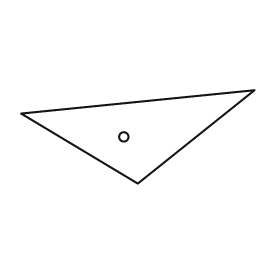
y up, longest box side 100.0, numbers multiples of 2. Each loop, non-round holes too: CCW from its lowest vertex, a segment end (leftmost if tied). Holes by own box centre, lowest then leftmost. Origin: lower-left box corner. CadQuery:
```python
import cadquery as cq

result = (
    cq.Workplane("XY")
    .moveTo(50.0, 0.0)
    .lineTo(100.0, 40.0)
    .lineTo(0.0, 30.0)
    .close()
    .moveTo(44.0, 20.0)
    .circle(2.0)
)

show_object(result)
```